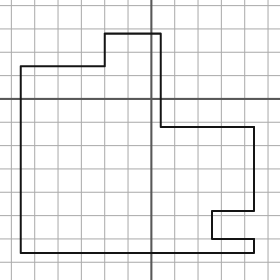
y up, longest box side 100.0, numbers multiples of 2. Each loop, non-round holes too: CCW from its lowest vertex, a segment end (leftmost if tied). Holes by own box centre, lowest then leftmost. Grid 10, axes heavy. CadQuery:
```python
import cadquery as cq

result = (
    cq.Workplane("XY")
    .moveTo(-56.0, -66.0)
    .lineTo(44.0, -66.0)
    .lineTo(44.0, -60.0)
    .lineTo(26.0, -60.0)
    .lineTo(26.0, -48.0)
    .lineTo(44.0, -48.0)
    .lineTo(44.0, -12.0)
    .lineTo(4.0, -12.0)
    .lineTo(4.0, 28.0)
    .lineTo(-20.0, 28.0)
    .lineTo(-20.0, 14.0)
    .lineTo(-56.0, 14.0)
    .close()
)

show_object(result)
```